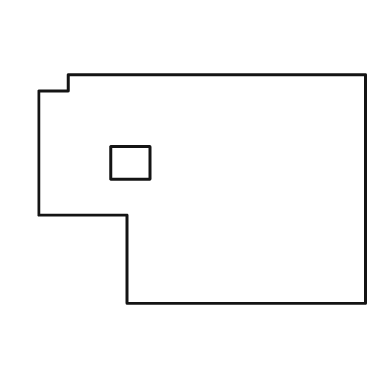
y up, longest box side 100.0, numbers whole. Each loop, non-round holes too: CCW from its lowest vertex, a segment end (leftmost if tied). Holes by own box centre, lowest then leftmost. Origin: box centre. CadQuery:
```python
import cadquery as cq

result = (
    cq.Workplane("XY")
    .moveTo(-23.0, -35.0)
    .lineTo(50.0, -35.0)
    .lineTo(50.0, 35.0)
    .lineTo(-41.0, 35.0)
    .lineTo(-41.0, 30.0)
    .lineTo(-50.0, 30.0)
    .lineTo(-50.0, -8.0)
    .lineTo(-23.0, -8.0)
    .close()
    .moveTo(-28.0, 3.0)
    .lineTo(-16.0, 3.0)
    .lineTo(-16.0, 13.0)
    .lineTo(-28.0, 13.0)
    .close()
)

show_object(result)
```